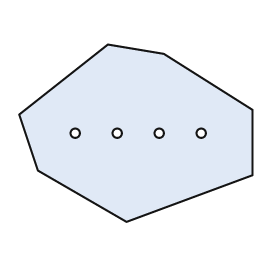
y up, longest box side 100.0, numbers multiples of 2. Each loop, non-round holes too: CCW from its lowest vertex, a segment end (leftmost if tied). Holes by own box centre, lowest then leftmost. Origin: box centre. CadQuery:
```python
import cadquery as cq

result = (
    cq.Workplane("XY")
    .moveTo(-4.0, -38.0)
    .lineTo(50.0, -18.0)
    .lineTo(50.0, 10.0)
    .lineTo(12.0, 34.0)
    .lineTo(-12.0, 38.0)
    .lineTo(-50.0, 8.0)
    .lineTo(-42.0, -16.0)
    .close()
    .moveTo(-26.0, 0.0)
    .circle(2.0)
    .moveTo(-8.0, 0.0)
    .circle(2.0)
    .moveTo(10.0, 0.0)
    .circle(2.0)
    .moveTo(28.0, 0.0)
    .circle(2.0)
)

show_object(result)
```